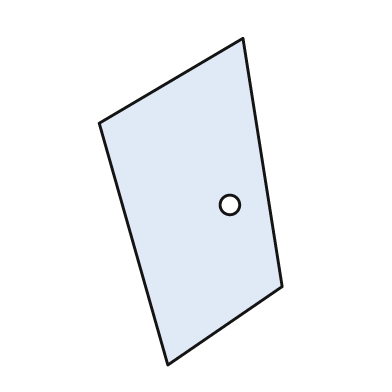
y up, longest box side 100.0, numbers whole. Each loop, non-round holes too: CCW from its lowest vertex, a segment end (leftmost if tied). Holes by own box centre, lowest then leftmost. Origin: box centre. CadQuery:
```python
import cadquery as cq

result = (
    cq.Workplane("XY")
    .moveTo(-7.0, -50.0)
    .lineTo(28.0, -26.0)
    .lineTo(16.0, 50.0)
    .lineTo(-28.0, 24.0)
    .close()
    .moveTo(12.0, -1.0)
    .circle(3.0)
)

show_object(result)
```